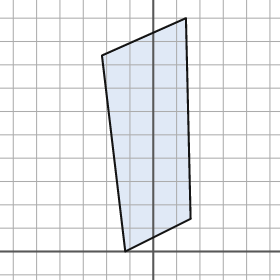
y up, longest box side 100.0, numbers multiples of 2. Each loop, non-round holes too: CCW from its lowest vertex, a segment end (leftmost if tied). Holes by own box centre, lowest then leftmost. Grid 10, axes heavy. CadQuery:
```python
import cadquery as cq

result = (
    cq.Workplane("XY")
    .moveTo(-12.0, 0.0)
    .lineTo(16.0, 14.0)
    .lineTo(14.0, 100.0)
    .lineTo(-22.0, 84.0)
    .close()
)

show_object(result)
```